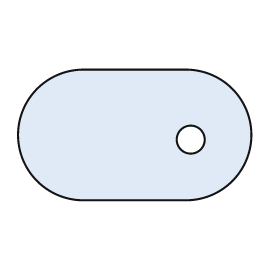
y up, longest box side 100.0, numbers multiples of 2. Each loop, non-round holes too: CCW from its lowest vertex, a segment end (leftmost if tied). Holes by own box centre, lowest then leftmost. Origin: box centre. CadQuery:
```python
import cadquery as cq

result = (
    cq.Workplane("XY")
    .moveTo(-22.0, -28.0)
    .lineTo(22.0, -28.0)
    .threePointArc((50.0, 0.0), (22.0, 28.0))
    .lineTo(-22.0, 28.0)
    .threePointArc((-50.0, 0.0), (-22.0, -28.0))
    .close()
    .moveTo(24.0, -2.0)
    .circle(6.0)
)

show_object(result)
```